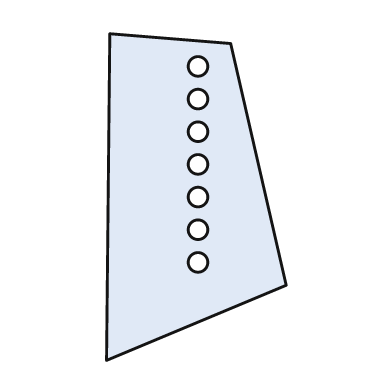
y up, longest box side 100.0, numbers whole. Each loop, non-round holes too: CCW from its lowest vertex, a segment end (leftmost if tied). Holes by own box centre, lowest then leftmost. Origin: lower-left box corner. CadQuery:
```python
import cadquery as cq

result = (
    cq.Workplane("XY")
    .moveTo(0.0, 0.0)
    .lineTo(55.0, 23.0)
    .lineTo(38.0, 97.0)
    .lineTo(1.0, 100.0)
    .close()
    .moveTo(28.0, 30.0)
    .circle(3.0)
    .moveTo(28.0, 40.0)
    .circle(3.0)
    .moveTo(28.0, 50.0)
    .circle(3.0)
    .moveTo(28.0, 60.0)
    .circle(3.0)
    .moveTo(28.0, 70.0)
    .circle(3.0)
    .moveTo(28.0, 80.0)
    .circle(3.0)
    .moveTo(28.0, 90.0)
    .circle(3.0)
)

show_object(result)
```